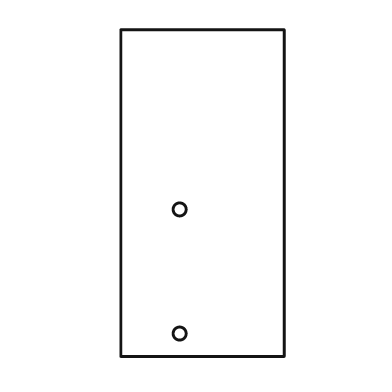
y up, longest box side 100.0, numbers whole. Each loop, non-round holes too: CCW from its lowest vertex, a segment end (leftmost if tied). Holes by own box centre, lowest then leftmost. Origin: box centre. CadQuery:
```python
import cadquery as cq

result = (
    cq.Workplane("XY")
    .moveTo(-25.0, -50.0)
    .lineTo(25.0, -50.0)
    .lineTo(25.0, 50.0)
    .lineTo(-25.0, 50.0)
    .close()
    .moveTo(-7.0, -43.0)
    .circle(2.0)
    .moveTo(-7.0, -5.0)
    .circle(2.0)
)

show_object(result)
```